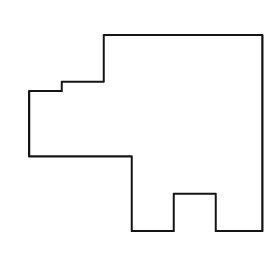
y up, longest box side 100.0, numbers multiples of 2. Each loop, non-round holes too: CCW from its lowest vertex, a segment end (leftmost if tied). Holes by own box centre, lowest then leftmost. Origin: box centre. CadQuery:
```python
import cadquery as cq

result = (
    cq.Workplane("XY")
    .moveTo(-6.0, -42.0)
    .lineTo(12.0, -42.0)
    .lineTo(12.0, -26.0)
    .lineTo(30.0, -26.0)
    .lineTo(30.0, -42.0)
    .lineTo(50.0, -42.0)
    .lineTo(50.0, 42.0)
    .lineTo(-18.0, 42.0)
    .lineTo(-18.0, 22.0)
    .lineTo(-36.0, 22.0)
    .lineTo(-36.0, 18.0)
    .lineTo(-50.0, 18.0)
    .lineTo(-50.0, -10.0)
    .lineTo(-6.0, -10.0)
    .close()
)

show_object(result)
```